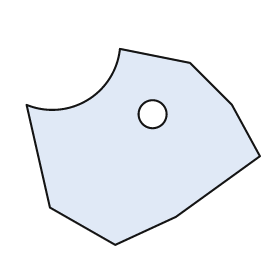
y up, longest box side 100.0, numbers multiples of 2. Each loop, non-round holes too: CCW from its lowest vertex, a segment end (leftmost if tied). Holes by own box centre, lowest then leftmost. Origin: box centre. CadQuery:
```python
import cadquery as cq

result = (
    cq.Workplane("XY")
    .moveTo(-12.0, -42.0)
    .lineTo(14.0, -30.0)
    .lineTo(50.0, -4.0)
    .lineTo(38.0, 18.0)
    .lineTo(20.0, 36.0)
    .lineTo(-10.0, 42.0)
    .threePointArc((-24.0, 20.0), (-50.0, 18.0))
    .lineTo(-40.0, -26.0)
    .close()
    .moveTo(4.0, 14.0)
    .circle(6.0)
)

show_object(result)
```